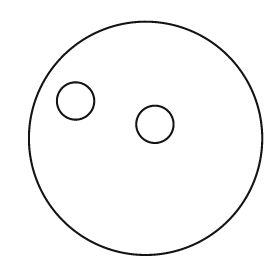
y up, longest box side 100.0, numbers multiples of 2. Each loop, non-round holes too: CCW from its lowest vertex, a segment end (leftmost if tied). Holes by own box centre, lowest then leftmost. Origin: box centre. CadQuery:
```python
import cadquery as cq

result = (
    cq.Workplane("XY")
    .moveTo(0.0, 0.0)
    .circle(50.0)
    .moveTo(4.0, 6.0)
    .circle(8.0)
    .moveTo(-30.0, 16.0)
    .circle(8.0)
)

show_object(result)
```